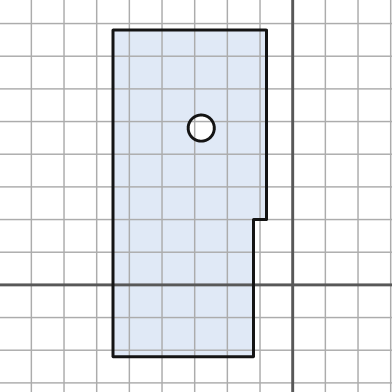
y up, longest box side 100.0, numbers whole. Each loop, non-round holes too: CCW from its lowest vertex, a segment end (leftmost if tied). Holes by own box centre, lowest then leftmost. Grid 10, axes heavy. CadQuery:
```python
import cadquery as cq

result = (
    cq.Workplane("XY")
    .moveTo(-55.0, -22.0)
    .lineTo(-12.0, -22.0)
    .lineTo(-12.0, 20.0)
    .lineTo(-8.0, 20.0)
    .lineTo(-8.0, 78.0)
    .lineTo(-55.0, 78.0)
    .close()
    .moveTo(-28.0, 48.0)
    .circle(4.0)
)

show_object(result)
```